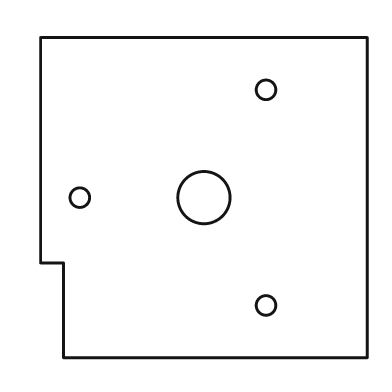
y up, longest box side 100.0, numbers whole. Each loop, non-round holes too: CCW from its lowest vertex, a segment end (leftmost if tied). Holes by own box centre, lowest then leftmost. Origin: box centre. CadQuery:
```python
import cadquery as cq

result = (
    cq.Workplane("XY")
    .moveTo(-43.0, -49.0)
    .lineTo(50.0, -49.0)
    .lineTo(50.0, 49.0)
    .lineTo(-50.0, 49.0)
    .lineTo(-50.0, -20.0)
    .lineTo(-43.0, -20.0)
    .close()
    .moveTo(19.0, -33.0)
    .circle(3.0)
    .moveTo(-38.0, 0.0)
    .circle(3.0)
    .moveTo(0.0, 0.0)
    .circle(8.0)
    .moveTo(19.0, 33.0)
    .circle(3.0)
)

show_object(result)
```